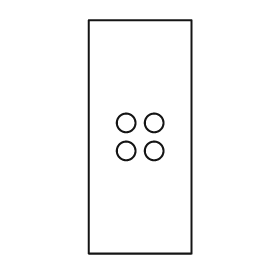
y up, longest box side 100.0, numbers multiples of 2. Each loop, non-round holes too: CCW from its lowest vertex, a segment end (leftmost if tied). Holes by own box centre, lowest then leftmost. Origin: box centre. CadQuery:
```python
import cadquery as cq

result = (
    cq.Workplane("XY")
    .moveTo(-22.0, -50.0)
    .lineTo(22.0, -50.0)
    .lineTo(22.0, 50.0)
    .lineTo(-22.0, 50.0)
    .close()
    .moveTo(-6.0, -6.0)
    .circle(4.0)
    .moveTo(6.0, -6.0)
    .circle(4.0)
    .moveTo(-6.0, 6.0)
    .circle(4.0)
    .moveTo(6.0, 6.0)
    .circle(4.0)
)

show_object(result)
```